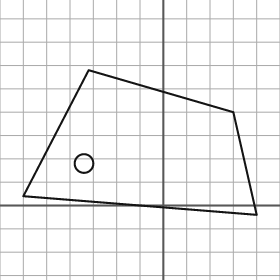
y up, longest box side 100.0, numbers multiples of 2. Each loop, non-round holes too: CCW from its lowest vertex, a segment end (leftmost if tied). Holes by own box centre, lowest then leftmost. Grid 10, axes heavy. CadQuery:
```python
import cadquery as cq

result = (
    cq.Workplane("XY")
    .moveTo(40.0, -4.0)
    .lineTo(30.0, 40.0)
    .lineTo(-32.0, 58.0)
    .lineTo(-60.0, 4.0)
    .close()
    .moveTo(-34.0, 18.0)
    .circle(4.0)
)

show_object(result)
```